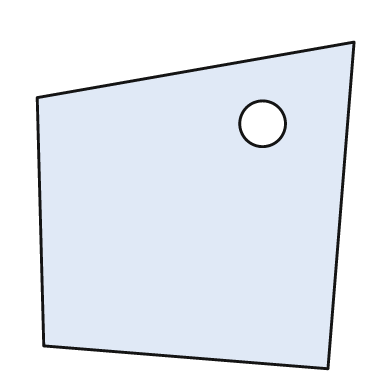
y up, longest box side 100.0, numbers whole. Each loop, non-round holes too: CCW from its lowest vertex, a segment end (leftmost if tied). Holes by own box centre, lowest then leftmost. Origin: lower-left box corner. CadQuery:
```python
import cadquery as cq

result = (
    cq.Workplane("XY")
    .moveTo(89.0, 0.0)
    .lineTo(97.0, 100.0)
    .lineTo(0.0, 83.0)
    .lineTo(2.0, 7.0)
    .close()
    .moveTo(69.0, 75.0)
    .circle(7.0)
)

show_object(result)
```